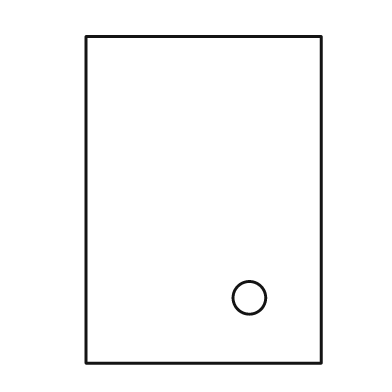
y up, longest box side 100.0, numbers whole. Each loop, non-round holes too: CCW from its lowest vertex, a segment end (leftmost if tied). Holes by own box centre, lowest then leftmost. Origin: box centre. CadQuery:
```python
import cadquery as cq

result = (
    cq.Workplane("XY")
    .moveTo(-36.0, -50.0)
    .lineTo(36.0, -50.0)
    .lineTo(36.0, 50.0)
    .lineTo(-36.0, 50.0)
    .close()
    .moveTo(14.0, -30.0)
    .circle(5.0)
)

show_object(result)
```